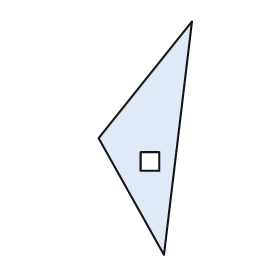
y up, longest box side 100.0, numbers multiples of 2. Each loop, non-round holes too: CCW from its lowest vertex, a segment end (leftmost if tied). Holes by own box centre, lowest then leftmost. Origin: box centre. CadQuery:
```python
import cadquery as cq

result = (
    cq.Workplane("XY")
    .moveTo(8.0, -50.0)
    .lineTo(20.0, 50.0)
    .lineTo(-20.0, 0.0)
    .close()
    .moveTo(-2.0, -14.0)
    .lineTo(6.0, -14.0)
    .lineTo(6.0, -6.0)
    .lineTo(-2.0, -6.0)
    .close()
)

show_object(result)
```